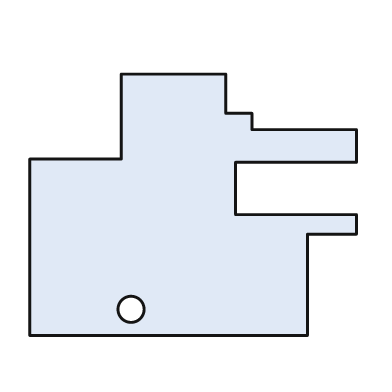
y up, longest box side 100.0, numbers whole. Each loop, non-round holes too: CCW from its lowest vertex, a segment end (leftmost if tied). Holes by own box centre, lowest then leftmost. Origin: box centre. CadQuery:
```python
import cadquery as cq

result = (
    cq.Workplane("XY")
    .moveTo(-50.0, -40.0)
    .lineTo(35.0, -40.0)
    .lineTo(35.0, -9.0)
    .lineTo(50.0, -9.0)
    .lineTo(50.0, -3.0)
    .lineTo(13.0, -3.0)
    .lineTo(13.0, 13.0)
    .lineTo(50.0, 13.0)
    .lineTo(50.0, 23.0)
    .lineTo(18.0, 23.0)
    .lineTo(18.0, 28.0)
    .lineTo(10.0, 28.0)
    .lineTo(10.0, 40.0)
    .lineTo(-22.0, 40.0)
    .lineTo(-22.0, 14.0)
    .lineTo(-50.0, 14.0)
    .close()
    .moveTo(-19.0, -32.0)
    .circle(4.0)
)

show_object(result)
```